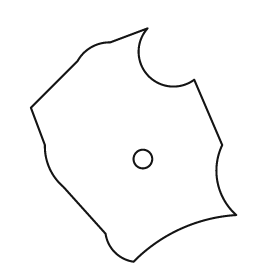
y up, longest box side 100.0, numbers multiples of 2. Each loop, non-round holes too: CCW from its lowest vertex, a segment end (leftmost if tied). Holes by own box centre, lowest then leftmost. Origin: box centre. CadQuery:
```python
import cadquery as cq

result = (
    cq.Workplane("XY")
    .moveTo(0.0, -50.0)
    .threePointArc((20.0, -36.0), (44.0, -30.0))
    .threePointArc((36.0, -16.0), (38.0, 0.0))
    .lineTo(26.0, 28.0)
    .threePointArc((6.0, 30.0), (6.0, 50.0))
    .lineTo(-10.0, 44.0)
    .threePointArc((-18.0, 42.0), (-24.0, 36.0))
    .lineTo(-44.0, 16.0)
    .lineTo(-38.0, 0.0)
    .threePointArc((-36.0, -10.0), (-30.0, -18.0))
    .lineTo(-12.0, -38.0)
    .threePointArc((-8.0, -46.0), (0.0, -50.0))
    .close()
    .moveTo(4.0, -6.0)
    .circle(4.0)
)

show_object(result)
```